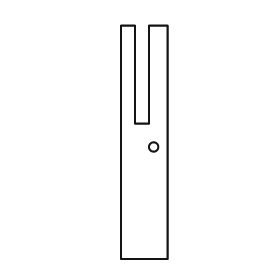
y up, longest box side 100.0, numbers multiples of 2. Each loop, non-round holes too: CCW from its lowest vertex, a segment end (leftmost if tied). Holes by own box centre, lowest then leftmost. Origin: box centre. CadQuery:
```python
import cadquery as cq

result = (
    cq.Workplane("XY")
    .moveTo(-10.0, -50.0)
    .lineTo(10.0, -50.0)
    .lineTo(10.0, 50.0)
    .lineTo(2.0, 50.0)
    .lineTo(2.0, 8.0)
    .lineTo(-4.0, 8.0)
    .lineTo(-4.0, 50.0)
    .lineTo(-10.0, 50.0)
    .close()
    .moveTo(4.0, -2.0)
    .circle(2.0)
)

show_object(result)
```